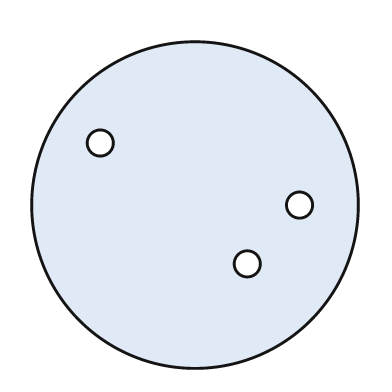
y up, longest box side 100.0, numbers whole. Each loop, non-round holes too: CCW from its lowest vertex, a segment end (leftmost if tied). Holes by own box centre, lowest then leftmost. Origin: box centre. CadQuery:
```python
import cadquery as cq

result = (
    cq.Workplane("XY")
    .moveTo(0.0, 0.0)
    .circle(50.0)
    .moveTo(16.0, -18.0)
    .circle(4.0)
    .moveTo(32.0, 0.0)
    .circle(4.0)
    .moveTo(-29.0, 19.0)
    .circle(4.0)
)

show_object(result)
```